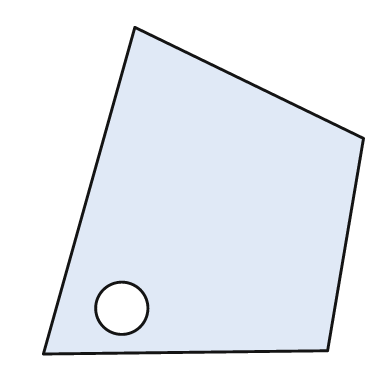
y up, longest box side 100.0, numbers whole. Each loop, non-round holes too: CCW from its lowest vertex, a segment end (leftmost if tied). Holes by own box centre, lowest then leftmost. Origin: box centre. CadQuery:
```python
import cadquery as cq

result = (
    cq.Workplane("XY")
    .moveTo(-49.0, -50.0)
    .lineTo(38.0, -49.0)
    .lineTo(49.0, 16.0)
    .lineTo(-21.0, 50.0)
    .close()
    .moveTo(-25.0, -36.0)
    .circle(8.0)
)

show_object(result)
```